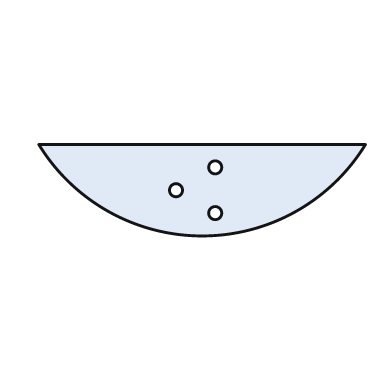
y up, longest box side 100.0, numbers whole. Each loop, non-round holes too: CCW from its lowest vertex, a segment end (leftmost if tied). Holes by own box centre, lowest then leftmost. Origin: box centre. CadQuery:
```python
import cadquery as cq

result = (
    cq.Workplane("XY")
    .moveTo(-50.0, 14.0)
    .threePointArc((0.0, -14.0), (50.0, 14.0))
    .close()
    .moveTo(4.0, -7.0)
    .circle(2.0)
    .moveTo(-8.0, 0.0)
    .circle(2.0)
    .moveTo(4.0, 7.0)
    .circle(2.0)
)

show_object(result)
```